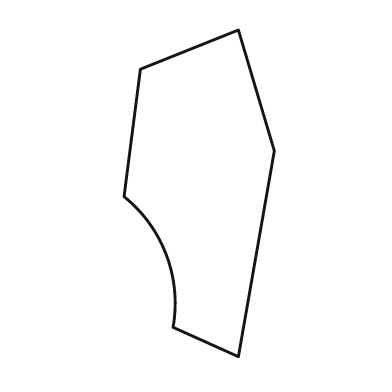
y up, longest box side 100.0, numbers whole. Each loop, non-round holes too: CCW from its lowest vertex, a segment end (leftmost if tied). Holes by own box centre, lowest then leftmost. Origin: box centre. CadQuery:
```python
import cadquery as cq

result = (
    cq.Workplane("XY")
    .moveTo(12.0, -50.0)
    .lineTo(23.0, 13.0)
    .lineTo(12.0, 50.0)
    .lineTo(-18.0, 38.0)
    .lineTo(-23.0, -1.0)
    .threePointArc((-10.0, -19.0), (-8.0, -41.0))
    .close()
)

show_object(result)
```